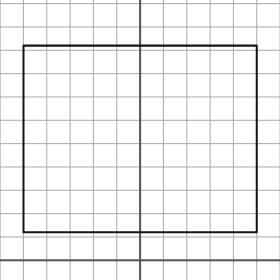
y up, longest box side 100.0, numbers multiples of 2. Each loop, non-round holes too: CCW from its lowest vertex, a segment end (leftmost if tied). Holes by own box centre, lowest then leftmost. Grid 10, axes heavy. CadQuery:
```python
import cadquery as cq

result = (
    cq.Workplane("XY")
    .moveTo(-50.0, 12.0)
    .lineTo(50.0, 12.0)
    .lineTo(50.0, 92.0)
    .lineTo(-50.0, 92.0)
    .close()
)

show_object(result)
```